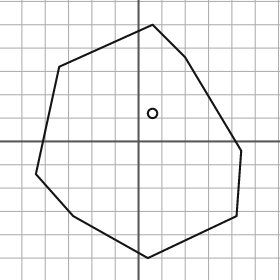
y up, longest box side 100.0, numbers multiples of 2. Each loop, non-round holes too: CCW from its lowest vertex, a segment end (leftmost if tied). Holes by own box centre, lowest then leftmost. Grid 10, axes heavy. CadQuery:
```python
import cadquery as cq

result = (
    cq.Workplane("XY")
    .moveTo(4.0, -50.0)
    .lineTo(42.0, -32.0)
    .lineTo(44.0, -4.0)
    .lineTo(20.0, 36.0)
    .lineTo(6.0, 50.0)
    .lineTo(-34.0, 32.0)
    .lineTo(-44.0, -14.0)
    .lineTo(-28.0, -32.0)
    .close()
    .moveTo(6.0, 12.0)
    .circle(2.0)
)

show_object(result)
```